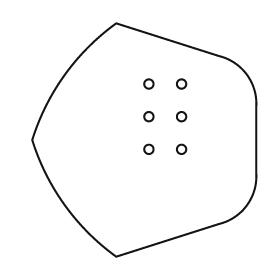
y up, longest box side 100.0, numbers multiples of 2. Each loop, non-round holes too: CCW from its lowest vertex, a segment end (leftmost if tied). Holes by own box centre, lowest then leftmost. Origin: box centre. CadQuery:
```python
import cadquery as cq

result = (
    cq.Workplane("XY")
    .moveTo(-12.0, -50.0)
    .lineTo(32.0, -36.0)
    .threePointArc((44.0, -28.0), (48.0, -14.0))
    .lineTo(48.0, 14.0)
    .threePointArc((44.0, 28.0), (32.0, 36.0))
    .lineTo(-12.0, 50.0)
    .threePointArc((-34.0, 28.0), (-48.0, 0.0))
    .threePointArc((-34.0, -28.0), (-12.0, -50.0))
    .close()
    .moveTo(2.0, -4.0)
    .circle(2.0)
    .moveTo(16.0, -4.0)
    .circle(2.0)
    .moveTo(2.0, 10.0)
    .circle(2.0)
    .moveTo(16.0, 10.0)
    .circle(2.0)
    .moveTo(2.0, 24.0)
    .circle(2.0)
    .moveTo(16.0, 24.0)
    .circle(2.0)
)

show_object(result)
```